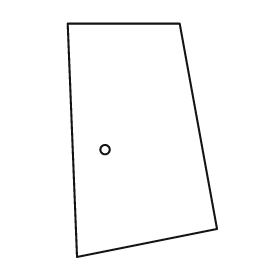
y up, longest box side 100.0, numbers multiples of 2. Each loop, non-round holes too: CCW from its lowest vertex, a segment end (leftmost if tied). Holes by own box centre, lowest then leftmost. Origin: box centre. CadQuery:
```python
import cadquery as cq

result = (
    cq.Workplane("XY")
    .moveTo(-28.0, -50.0)
    .lineTo(32.0, -38.0)
    .lineTo(16.0, 50.0)
    .lineTo(-32.0, 50.0)
    .close()
    .moveTo(-16.0, -4.0)
    .circle(2.0)
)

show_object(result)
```